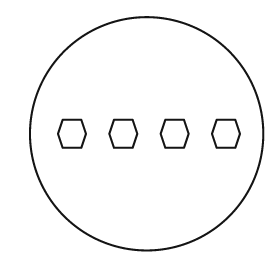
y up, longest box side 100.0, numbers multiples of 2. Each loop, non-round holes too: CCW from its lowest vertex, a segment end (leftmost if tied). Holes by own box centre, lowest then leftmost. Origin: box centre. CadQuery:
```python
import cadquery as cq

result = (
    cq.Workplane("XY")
    .moveTo(0.0, 0.0)
    .circle(50.0)
    .moveTo(-36.0, -6.0)
    .lineTo(-28.0, -6.0)
    .lineTo(-26.0, 0.0)
    .lineTo(-28.0, 6.0)
    .lineTo(-36.0, 6.0)
    .lineTo(-38.0, 0.0)
    .close()
    .moveTo(-14.0, -6.0)
    .lineTo(-6.0, -6.0)
    .lineTo(-4.0, 0.0)
    .lineTo(-6.0, 6.0)
    .lineTo(-14.0, 6.0)
    .lineTo(-16.0, 0.0)
    .close()
    .moveTo(8.0, -6.0)
    .lineTo(16.0, -6.0)
    .lineTo(18.0, 0.0)
    .lineTo(16.0, 6.0)
    .lineTo(8.0, 6.0)
    .lineTo(6.0, 0.0)
    .close()
    .moveTo(30.0, -6.0)
    .lineTo(38.0, -6.0)
    .lineTo(40.0, 0.0)
    .lineTo(38.0, 6.0)
    .lineTo(30.0, 6.0)
    .lineTo(28.0, 0.0)
    .close()
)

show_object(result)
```